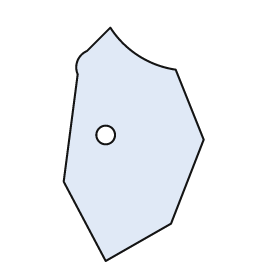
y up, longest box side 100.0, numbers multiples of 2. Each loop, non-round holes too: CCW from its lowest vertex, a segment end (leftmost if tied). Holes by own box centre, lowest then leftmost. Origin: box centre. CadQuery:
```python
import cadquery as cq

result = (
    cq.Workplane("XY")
    .moveTo(-12.0, -50.0)
    .lineTo(16.0, -34.0)
    .lineTo(30.0, 2.0)
    .lineTo(18.0, 32.0)
    .threePointArc((2.0, 38.0), (-10.0, 50.0))
    .lineTo(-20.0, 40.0)
    .threePointArc((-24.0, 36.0), (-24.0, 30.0))
    .lineTo(-30.0, -16.0)
    .close()
    .moveTo(-12.0, 4.0)
    .circle(4.0)
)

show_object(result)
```